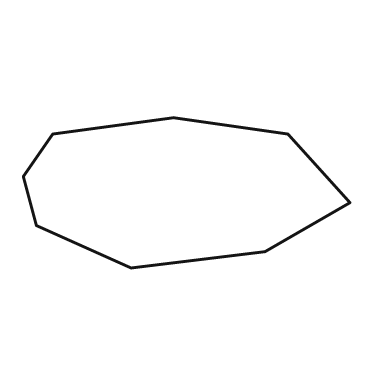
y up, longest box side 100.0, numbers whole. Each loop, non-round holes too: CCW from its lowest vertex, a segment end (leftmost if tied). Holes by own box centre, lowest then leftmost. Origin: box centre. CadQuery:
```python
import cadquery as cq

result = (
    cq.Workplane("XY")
    .moveTo(-17.0, -23.0)
    .lineTo(24.0, -18.0)
    .lineTo(50.0, -3.0)
    .lineTo(31.0, 18.0)
    .lineTo(-4.0, 23.0)
    .lineTo(-41.0, 18.0)
    .lineTo(-50.0, 5.0)
    .lineTo(-46.0, -10.0)
    .close()
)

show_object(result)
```